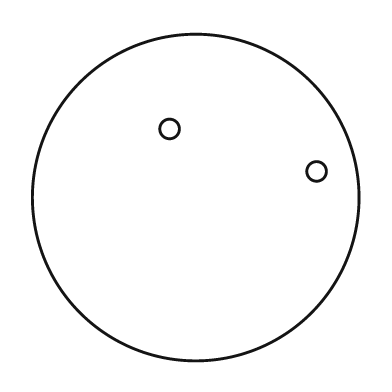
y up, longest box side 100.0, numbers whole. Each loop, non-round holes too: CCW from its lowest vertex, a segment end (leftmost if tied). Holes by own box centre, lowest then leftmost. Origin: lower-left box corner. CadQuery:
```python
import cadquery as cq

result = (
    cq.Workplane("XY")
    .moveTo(50.0, 50.0)
    .circle(50.0)
    .moveTo(87.0, 58.0)
    .circle(3.0)
    .moveTo(42.0, 71.0)
    .circle(3.0)
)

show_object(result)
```